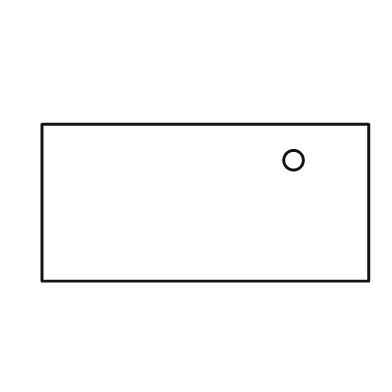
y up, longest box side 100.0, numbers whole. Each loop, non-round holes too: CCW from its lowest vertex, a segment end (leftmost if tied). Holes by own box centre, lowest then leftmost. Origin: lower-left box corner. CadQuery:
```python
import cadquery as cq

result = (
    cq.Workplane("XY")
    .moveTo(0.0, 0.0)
    .lineTo(100.0, 0.0)
    .lineTo(100.0, 48.0)
    .lineTo(0.0, 48.0)
    .close()
    .moveTo(77.0, 37.0)
    .circle(3.0)
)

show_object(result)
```